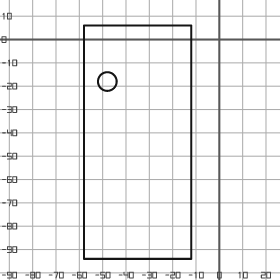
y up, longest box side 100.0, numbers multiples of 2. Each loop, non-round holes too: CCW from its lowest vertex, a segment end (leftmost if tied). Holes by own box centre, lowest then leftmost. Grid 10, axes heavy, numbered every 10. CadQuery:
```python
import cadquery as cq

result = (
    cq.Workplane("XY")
    .moveTo(-58.0, -94.0)
    .lineTo(-12.0, -94.0)
    .lineTo(-12.0, 6.0)
    .lineTo(-58.0, 6.0)
    .close()
    .moveTo(-48.0, -18.0)
    .circle(4.0)
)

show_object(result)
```